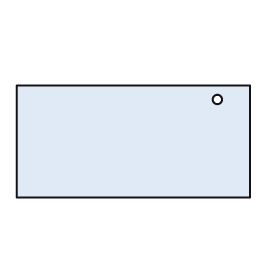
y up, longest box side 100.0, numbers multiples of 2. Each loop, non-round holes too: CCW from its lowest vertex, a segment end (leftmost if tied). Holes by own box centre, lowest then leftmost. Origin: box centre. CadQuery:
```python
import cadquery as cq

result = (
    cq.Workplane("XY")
    .moveTo(-50.0, -24.0)
    .lineTo(50.0, -24.0)
    .lineTo(50.0, 24.0)
    .lineTo(-50.0, 24.0)
    .close()
    .moveTo(36.0, 18.0)
    .circle(2.0)
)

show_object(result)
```